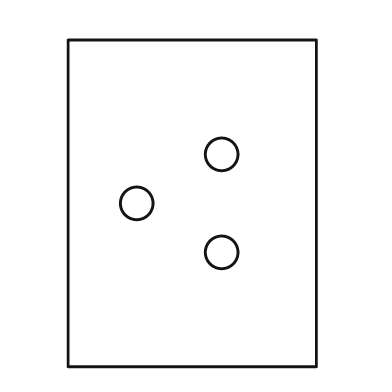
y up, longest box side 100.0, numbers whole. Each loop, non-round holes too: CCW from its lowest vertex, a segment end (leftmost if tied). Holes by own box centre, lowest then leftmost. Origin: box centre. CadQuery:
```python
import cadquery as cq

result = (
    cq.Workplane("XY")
    .moveTo(-38.0, -50.0)
    .lineTo(38.0, -50.0)
    .lineTo(38.0, 50.0)
    .lineTo(-38.0, 50.0)
    .close()
    .moveTo(9.0, -15.0)
    .circle(5.0)
    .moveTo(-17.0, 0.0)
    .circle(5.0)
    .moveTo(9.0, 15.0)
    .circle(5.0)
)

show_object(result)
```